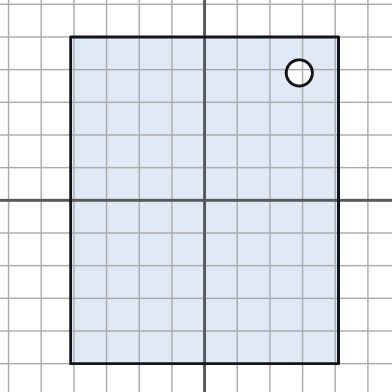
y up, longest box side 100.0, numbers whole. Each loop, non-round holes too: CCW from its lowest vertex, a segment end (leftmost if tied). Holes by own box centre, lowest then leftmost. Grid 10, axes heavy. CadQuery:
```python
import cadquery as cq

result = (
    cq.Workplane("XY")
    .moveTo(-41.0, -50.0)
    .lineTo(41.0, -50.0)
    .lineTo(41.0, 50.0)
    .lineTo(-41.0, 50.0)
    .close()
    .moveTo(29.0, 39.0)
    .circle(4.0)
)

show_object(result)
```